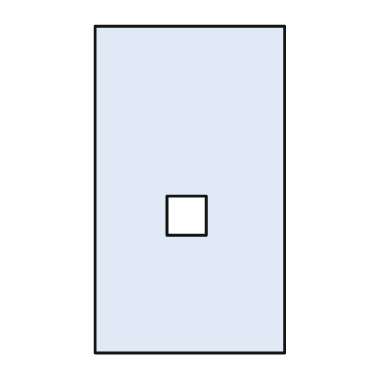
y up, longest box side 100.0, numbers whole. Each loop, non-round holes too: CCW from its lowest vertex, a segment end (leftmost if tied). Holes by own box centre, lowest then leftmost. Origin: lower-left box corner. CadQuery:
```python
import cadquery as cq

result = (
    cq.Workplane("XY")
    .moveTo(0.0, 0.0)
    .lineTo(58.0, 0.0)
    .lineTo(58.0, 100.0)
    .lineTo(0.0, 100.0)
    .close()
    .moveTo(22.0, 36.0)
    .lineTo(34.0, 36.0)
    .lineTo(34.0, 48.0)
    .lineTo(22.0, 48.0)
    .close()
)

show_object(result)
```